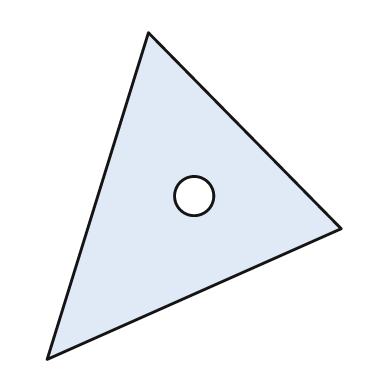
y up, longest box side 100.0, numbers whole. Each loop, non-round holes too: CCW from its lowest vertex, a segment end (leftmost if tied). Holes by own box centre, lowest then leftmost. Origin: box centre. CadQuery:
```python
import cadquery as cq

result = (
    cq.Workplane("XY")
    .moveTo(-45.0, -50.0)
    .lineTo(45.0, -10.0)
    .lineTo(-14.0, 50.0)
    .close()
    .moveTo(0.0, 0.0)
    .circle(6.0)
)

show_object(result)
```